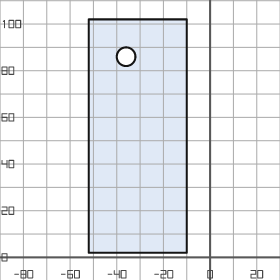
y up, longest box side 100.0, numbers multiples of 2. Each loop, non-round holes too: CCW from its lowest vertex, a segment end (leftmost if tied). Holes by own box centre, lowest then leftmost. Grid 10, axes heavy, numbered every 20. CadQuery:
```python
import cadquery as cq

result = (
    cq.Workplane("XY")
    .moveTo(-52.0, 2.0)
    .lineTo(-10.0, 2.0)
    .lineTo(-10.0, 102.0)
    .lineTo(-52.0, 102.0)
    .close()
    .moveTo(-36.0, 86.0)
    .circle(4.0)
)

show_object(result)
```